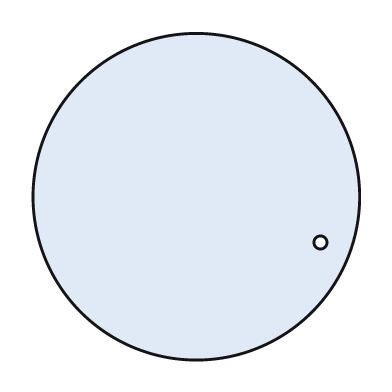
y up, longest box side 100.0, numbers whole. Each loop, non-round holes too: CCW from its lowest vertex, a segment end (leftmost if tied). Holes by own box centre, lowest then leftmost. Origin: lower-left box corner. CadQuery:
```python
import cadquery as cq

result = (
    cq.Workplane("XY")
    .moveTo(50.0, 50.0)
    .circle(50.0)
    .moveTo(88.0, 36.0)
    .circle(2.0)
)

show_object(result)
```